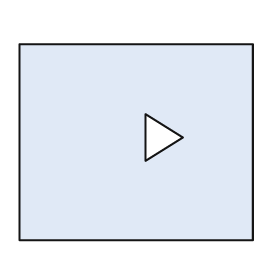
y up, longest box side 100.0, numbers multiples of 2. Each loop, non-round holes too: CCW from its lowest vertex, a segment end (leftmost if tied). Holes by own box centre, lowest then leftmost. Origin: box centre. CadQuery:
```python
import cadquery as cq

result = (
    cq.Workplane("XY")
    .moveTo(-50.0, -42.0)
    .lineTo(50.0, -42.0)
    .lineTo(50.0, 42.0)
    .lineTo(-50.0, 42.0)
    .close()
    .moveTo(4.0, -8.0)
    .lineTo(20.0, 2.0)
    .lineTo(4.0, 12.0)
    .close()
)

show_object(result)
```